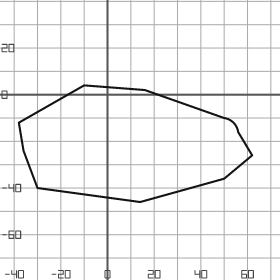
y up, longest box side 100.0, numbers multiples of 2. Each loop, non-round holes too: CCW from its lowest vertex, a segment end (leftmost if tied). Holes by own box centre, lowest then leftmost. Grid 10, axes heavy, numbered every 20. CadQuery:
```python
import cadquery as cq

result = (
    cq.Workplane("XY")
    .moveTo(14.0, -46.0)
    .lineTo(50.0, -36.0)
    .lineTo(62.0, -26.0)
    .lineTo(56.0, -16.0)
    .threePointArc((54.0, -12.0), (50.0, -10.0))
    .lineTo(16.0, 2.0)
    .lineTo(-10.0, 4.0)
    .lineTo(-38.0, -12.0)
    .lineTo(-36.0, -24.0)
    .lineTo(-30.0, -40.0)
    .close()
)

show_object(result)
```